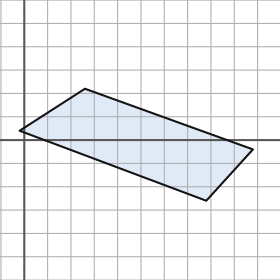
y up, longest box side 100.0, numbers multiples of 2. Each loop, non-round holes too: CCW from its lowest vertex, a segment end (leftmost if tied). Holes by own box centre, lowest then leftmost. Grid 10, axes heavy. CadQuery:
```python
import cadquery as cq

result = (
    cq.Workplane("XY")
    .moveTo(78.0, -26.0)
    .lineTo(98.0, -4.0)
    .lineTo(26.0, 22.0)
    .lineTo(-2.0, 4.0)
    .close()
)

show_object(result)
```